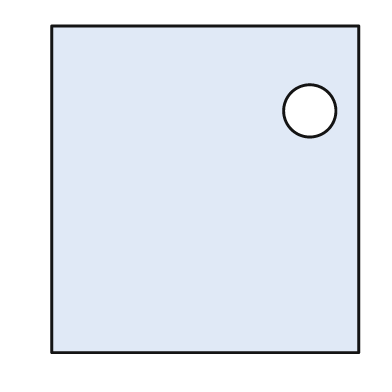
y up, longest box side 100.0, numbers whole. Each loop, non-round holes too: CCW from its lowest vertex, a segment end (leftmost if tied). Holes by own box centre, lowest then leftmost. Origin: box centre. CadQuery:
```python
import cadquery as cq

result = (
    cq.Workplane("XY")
    .moveTo(-47.0, -50.0)
    .lineTo(47.0, -50.0)
    .lineTo(47.0, 50.0)
    .lineTo(-47.0, 50.0)
    .close()
    .moveTo(32.0, 24.0)
    .circle(8.0)
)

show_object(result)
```